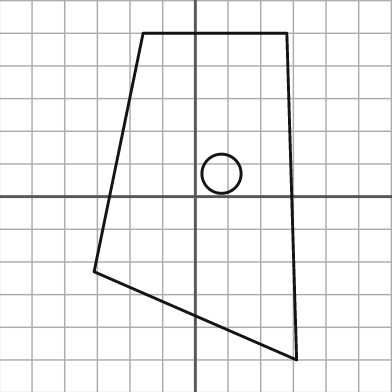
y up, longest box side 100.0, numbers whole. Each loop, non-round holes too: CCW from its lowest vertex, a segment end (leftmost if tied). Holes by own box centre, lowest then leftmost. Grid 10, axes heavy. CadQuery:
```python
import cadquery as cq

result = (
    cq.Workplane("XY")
    .moveTo(31.0, -50.0)
    .lineTo(28.0, 50.0)
    .lineTo(-16.0, 50.0)
    .lineTo(-31.0, -23.0)
    .close()
    .moveTo(8.0, 7.0)
    .circle(6.0)
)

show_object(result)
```